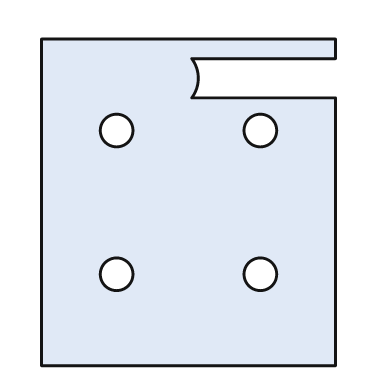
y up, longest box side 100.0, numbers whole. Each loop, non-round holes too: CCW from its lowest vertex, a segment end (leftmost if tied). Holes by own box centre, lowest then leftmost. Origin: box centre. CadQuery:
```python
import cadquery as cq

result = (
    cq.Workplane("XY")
    .moveTo(-45.0, -50.0)
    .lineTo(45.0, -50.0)
    .lineTo(45.0, 32.0)
    .lineTo(1.0, 32.0)
    .threePointArc((3.0, 38.0), (1.0, 44.0))
    .lineTo(45.0, 44.0)
    .lineTo(45.0, 50.0)
    .lineTo(-45.0, 50.0)
    .close()
    .moveTo(-22.0, -22.0)
    .circle(5.0)
    .moveTo(22.0, -22.0)
    .circle(5.0)
    .moveTo(-22.0, 22.0)
    .circle(5.0)
    .moveTo(22.0, 22.0)
    .circle(5.0)
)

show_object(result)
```